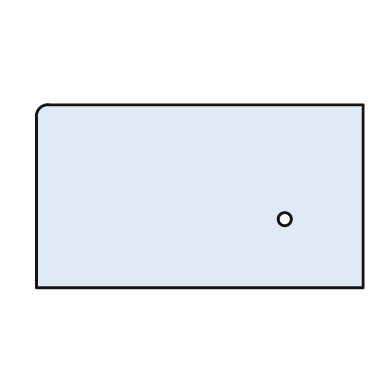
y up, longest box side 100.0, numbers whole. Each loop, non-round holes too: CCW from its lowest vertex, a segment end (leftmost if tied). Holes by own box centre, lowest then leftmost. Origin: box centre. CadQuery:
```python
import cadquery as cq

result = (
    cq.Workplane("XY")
    .moveTo(-50.0, -28.0)
    .lineTo(50.0, -28.0)
    .lineTo(50.0, 28.0)
    .lineTo(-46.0, 28.0)
    .threePointArc((-49.0, 27.0), (-50.0, 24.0))
    .close()
    .moveTo(26.0, -7.0)
    .circle(2.0)
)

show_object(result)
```